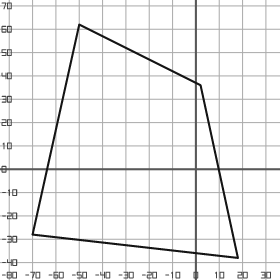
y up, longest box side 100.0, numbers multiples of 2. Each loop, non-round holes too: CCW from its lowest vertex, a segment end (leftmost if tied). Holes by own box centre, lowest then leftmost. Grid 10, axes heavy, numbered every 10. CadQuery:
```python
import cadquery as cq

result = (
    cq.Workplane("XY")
    .moveTo(18.0, -38.0)
    .lineTo(2.0, 36.0)
    .lineTo(-50.0, 62.0)
    .lineTo(-70.0, -28.0)
    .close()
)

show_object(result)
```